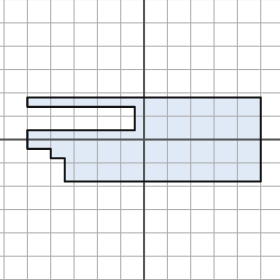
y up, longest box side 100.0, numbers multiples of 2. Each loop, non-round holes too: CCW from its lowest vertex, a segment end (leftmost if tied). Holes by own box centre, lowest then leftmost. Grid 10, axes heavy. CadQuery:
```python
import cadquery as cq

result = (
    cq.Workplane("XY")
    .moveTo(-34.0, -18.0)
    .lineTo(50.0, -18.0)
    .lineTo(50.0, 18.0)
    .lineTo(-50.0, 18.0)
    .lineTo(-50.0, 14.0)
    .lineTo(-4.0, 14.0)
    .lineTo(-4.0, 4.0)
    .lineTo(-50.0, 4.0)
    .lineTo(-50.0, -4.0)
    .lineTo(-40.0, -4.0)
    .lineTo(-40.0, -8.0)
    .lineTo(-34.0, -8.0)
    .close()
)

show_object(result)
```